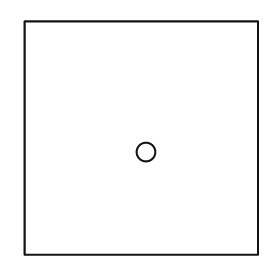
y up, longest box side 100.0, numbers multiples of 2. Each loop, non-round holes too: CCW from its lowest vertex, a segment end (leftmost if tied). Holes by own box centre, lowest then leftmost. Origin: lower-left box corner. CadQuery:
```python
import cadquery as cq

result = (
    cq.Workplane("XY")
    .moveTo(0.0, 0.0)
    .lineTo(100.0, 0.0)
    .lineTo(100.0, 100.0)
    .lineTo(0.0, 100.0)
    .close()
    .moveTo(52.0, 44.0)
    .circle(4.0)
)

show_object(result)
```